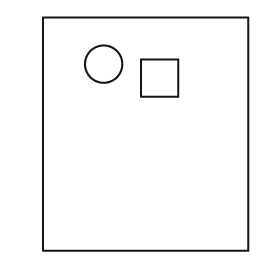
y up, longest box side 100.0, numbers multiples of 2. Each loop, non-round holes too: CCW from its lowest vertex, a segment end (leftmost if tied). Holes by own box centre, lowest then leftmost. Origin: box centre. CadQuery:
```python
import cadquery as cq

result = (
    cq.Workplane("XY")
    .moveTo(-44.0, -50.0)
    .lineTo(44.0, -50.0)
    .lineTo(44.0, 50.0)
    .lineTo(-44.0, 50.0)
    .close()
    .moveTo(-2.0, 16.0)
    .lineTo(14.0, 16.0)
    .lineTo(14.0, 32.0)
    .lineTo(-2.0, 32.0)
    .close()
    .moveTo(-18.0, 30.0)
    .circle(8.0)
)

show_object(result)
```